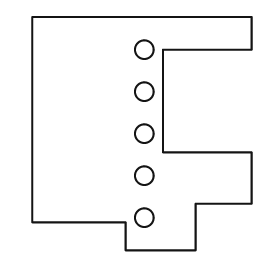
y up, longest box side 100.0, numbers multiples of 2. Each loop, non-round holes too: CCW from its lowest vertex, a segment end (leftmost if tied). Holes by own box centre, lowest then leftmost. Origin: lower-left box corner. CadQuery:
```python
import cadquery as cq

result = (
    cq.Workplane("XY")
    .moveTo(40.0, 0.0)
    .lineTo(70.0, 0.0)
    .lineTo(70.0, 20.0)
    .lineTo(94.0, 20.0)
    .lineTo(94.0, 42.0)
    .lineTo(56.0, 42.0)
    .lineTo(56.0, 86.0)
    .lineTo(94.0, 86.0)
    .lineTo(94.0, 100.0)
    .lineTo(0.0, 100.0)
    .lineTo(0.0, 12.0)
    .lineTo(40.0, 12.0)
    .close()
    .moveTo(48.0, 14.0)
    .circle(4.0)
    .moveTo(48.0, 32.0)
    .circle(4.0)
    .moveTo(48.0, 50.0)
    .circle(4.0)
    .moveTo(48.0, 68.0)
    .circle(4.0)
    .moveTo(48.0, 86.0)
    .circle(4.0)
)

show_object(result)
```